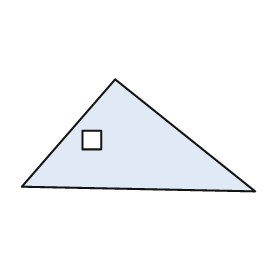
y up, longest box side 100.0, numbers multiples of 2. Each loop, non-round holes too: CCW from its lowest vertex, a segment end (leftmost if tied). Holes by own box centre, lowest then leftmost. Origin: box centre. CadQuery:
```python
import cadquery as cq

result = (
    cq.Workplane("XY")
    .moveTo(50.0, -24.0)
    .lineTo(-10.0, 24.0)
    .lineTo(-50.0, -22.0)
    .close()
    .moveTo(-24.0, -6.0)
    .lineTo(-16.0, -6.0)
    .lineTo(-16.0, 2.0)
    .lineTo(-24.0, 2.0)
    .close()
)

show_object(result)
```